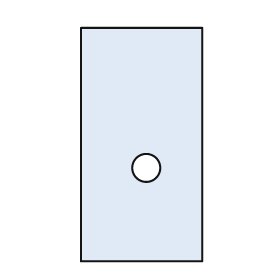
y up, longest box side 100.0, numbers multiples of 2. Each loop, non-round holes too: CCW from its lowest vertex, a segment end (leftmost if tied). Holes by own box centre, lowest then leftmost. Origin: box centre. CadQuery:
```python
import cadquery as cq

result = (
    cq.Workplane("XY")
    .moveTo(-26.0, -50.0)
    .lineTo(26.0, -50.0)
    .lineTo(26.0, 50.0)
    .lineTo(-26.0, 50.0)
    .close()
    .moveTo(2.0, -10.0)
    .circle(6.0)
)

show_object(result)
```